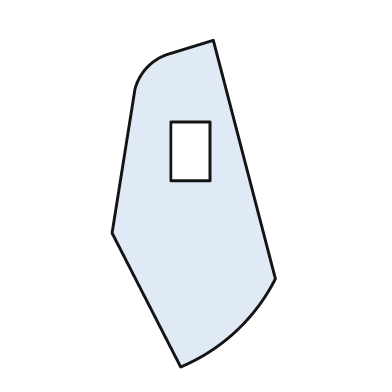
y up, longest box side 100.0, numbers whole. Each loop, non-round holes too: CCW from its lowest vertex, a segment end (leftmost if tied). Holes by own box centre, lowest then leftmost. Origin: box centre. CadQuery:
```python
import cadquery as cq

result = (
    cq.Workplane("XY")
    .moveTo(-4.0, -50.0)
    .threePointArc((13.0, -39.0), (25.0, -23.0))
    .lineTo(6.0, 50.0)
    .lineTo(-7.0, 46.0)
    .threePointArc((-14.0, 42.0), (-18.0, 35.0))
    .lineTo(-25.0, -9.0)
    .close()
    .moveTo(-7.0, 7.0)
    .lineTo(5.0, 7.0)
    .lineTo(5.0, 25.0)
    .lineTo(-7.0, 25.0)
    .close()
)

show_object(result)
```